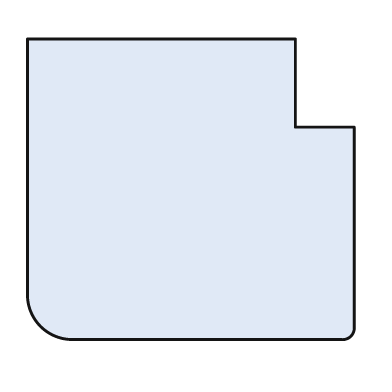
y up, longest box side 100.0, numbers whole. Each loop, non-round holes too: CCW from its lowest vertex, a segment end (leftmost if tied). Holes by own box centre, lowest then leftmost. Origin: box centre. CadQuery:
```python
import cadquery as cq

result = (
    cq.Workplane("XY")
    .moveTo(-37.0, -46.0)
    .lineTo(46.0, -46.0)
    .threePointArc((49.0, -45.0), (50.0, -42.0))
    .lineTo(50.0, 19.0)
    .lineTo(32.0, 19.0)
    .lineTo(32.0, 46.0)
    .lineTo(-50.0, 46.0)
    .lineTo(-50.0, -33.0)
    .threePointArc((-46.0, -42.0), (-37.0, -46.0))
    .close()
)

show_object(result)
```